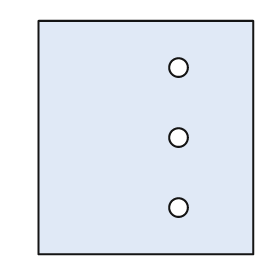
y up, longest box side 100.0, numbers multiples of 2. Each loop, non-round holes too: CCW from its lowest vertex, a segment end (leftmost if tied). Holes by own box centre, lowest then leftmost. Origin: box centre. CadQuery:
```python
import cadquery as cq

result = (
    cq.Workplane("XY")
    .moveTo(-46.0, -50.0)
    .lineTo(46.0, -50.0)
    .lineTo(46.0, 50.0)
    .lineTo(-46.0, 50.0)
    .close()
    .moveTo(14.0, -30.0)
    .circle(4.0)
    .moveTo(14.0, 0.0)
    .circle(4.0)
    .moveTo(14.0, 30.0)
    .circle(4.0)
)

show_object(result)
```